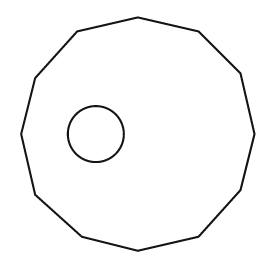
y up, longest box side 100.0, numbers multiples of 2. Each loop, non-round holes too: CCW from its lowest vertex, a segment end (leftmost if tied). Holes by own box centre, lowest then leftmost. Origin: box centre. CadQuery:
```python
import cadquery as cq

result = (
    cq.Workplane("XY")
    .moveTo(0.0, -50.0)
    .lineTo(26.0, -44.0)
    .lineTo(44.0, -24.0)
    .lineTo(50.0, 0.0)
    .lineTo(44.0, 26.0)
    .lineTo(26.0, 44.0)
    .lineTo(0.0, 50.0)
    .lineTo(-26.0, 44.0)
    .lineTo(-44.0, 24.0)
    .lineTo(-50.0, 0.0)
    .lineTo(-44.0, -26.0)
    .lineTo(-24.0, -44.0)
    .close()
    .moveTo(-18.0, 0.0)
    .circle(12.0)
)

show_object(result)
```